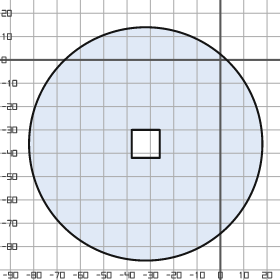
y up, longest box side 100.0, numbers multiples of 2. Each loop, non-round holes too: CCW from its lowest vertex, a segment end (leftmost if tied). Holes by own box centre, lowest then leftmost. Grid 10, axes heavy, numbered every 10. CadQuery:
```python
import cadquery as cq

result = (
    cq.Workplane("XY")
    .moveTo(-32.0, -36.0)
    .circle(50.0)
    .moveTo(-38.0, -42.0)
    .lineTo(-26.0, -42.0)
    .lineTo(-26.0, -30.0)
    .lineTo(-38.0, -30.0)
    .close()
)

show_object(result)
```